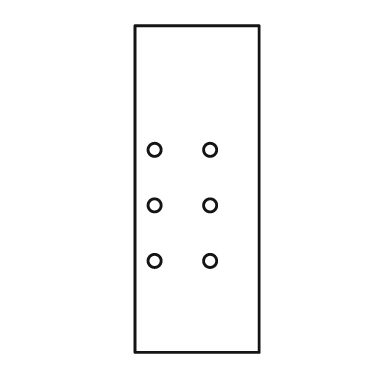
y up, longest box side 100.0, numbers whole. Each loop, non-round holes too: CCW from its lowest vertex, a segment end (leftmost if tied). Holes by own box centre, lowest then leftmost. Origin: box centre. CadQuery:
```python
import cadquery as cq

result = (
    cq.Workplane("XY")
    .moveTo(-19.0, -50.0)
    .lineTo(19.0, -50.0)
    .lineTo(19.0, 50.0)
    .lineTo(-19.0, 50.0)
    .close()
    .moveTo(-13.0, -22.0)
    .circle(2.0)
    .moveTo(4.0, -22.0)
    .circle(2.0)
    .moveTo(-13.0, -5.0)
    .circle(2.0)
    .moveTo(4.0, -5.0)
    .circle(2.0)
    .moveTo(-13.0, 12.0)
    .circle(2.0)
    .moveTo(4.0, 12.0)
    .circle(2.0)
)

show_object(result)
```